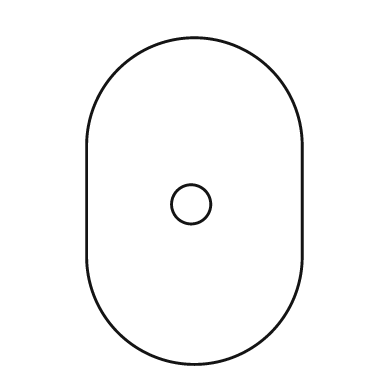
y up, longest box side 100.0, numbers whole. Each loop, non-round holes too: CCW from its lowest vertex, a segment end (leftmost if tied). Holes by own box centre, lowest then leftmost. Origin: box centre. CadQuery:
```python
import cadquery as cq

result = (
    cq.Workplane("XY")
    .moveTo(-33.0, -17.0)
    .threePointArc((0.0, -50.0), (33.0, -17.0))
    .lineTo(33.0, 17.0)
    .threePointArc((0.0, 50.0), (-33.0, 17.0))
    .close()
    .moveTo(-1.0, -1.0)
    .circle(6.0)
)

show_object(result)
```